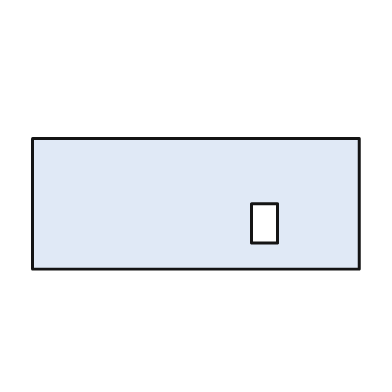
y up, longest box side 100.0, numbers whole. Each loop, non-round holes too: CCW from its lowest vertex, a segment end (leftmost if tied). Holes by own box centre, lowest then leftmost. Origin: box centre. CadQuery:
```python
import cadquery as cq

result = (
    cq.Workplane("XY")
    .moveTo(-50.0, -20.0)
    .lineTo(50.0, -20.0)
    .lineTo(50.0, 20.0)
    .lineTo(-50.0, 20.0)
    .close()
    .moveTo(17.0, -12.0)
    .lineTo(25.0, -12.0)
    .lineTo(25.0, 0.0)
    .lineTo(17.0, 0.0)
    .close()
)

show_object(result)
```